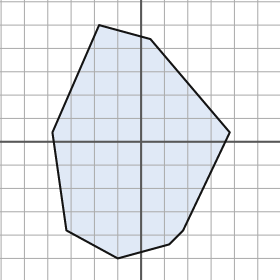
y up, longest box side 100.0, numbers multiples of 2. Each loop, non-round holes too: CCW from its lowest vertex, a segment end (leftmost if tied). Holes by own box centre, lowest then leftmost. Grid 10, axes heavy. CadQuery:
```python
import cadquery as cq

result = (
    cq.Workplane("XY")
    .moveTo(-10.0, -50.0)
    .lineTo(12.0, -44.0)
    .lineTo(18.0, -38.0)
    .lineTo(38.0, 4.0)
    .lineTo(4.0, 44.0)
    .lineTo(-18.0, 50.0)
    .lineTo(-38.0, 4.0)
    .lineTo(-32.0, -38.0)
    .close()
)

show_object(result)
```